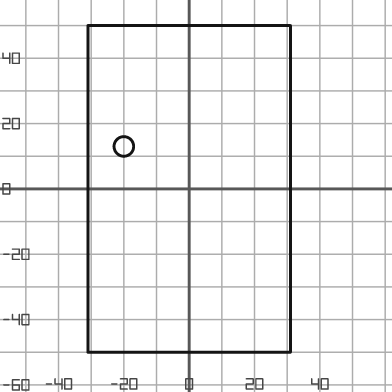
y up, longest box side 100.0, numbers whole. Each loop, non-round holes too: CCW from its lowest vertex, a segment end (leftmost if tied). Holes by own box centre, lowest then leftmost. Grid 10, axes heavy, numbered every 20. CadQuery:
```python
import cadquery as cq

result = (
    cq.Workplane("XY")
    .moveTo(-31.0, -50.0)
    .lineTo(31.0, -50.0)
    .lineTo(31.0, 50.0)
    .lineTo(-31.0, 50.0)
    .close()
    .moveTo(-20.0, 13.0)
    .circle(3.0)
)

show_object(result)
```